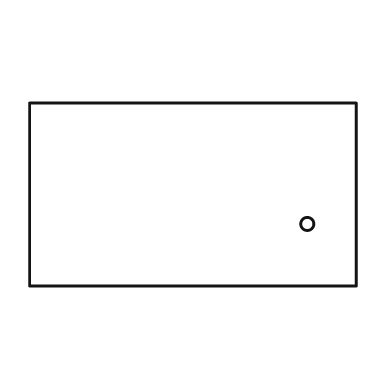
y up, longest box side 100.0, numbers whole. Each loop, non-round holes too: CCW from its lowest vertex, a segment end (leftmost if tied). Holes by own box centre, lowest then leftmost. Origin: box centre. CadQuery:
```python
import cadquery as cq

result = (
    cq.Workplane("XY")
    .moveTo(-50.0, -28.0)
    .lineTo(50.0, -28.0)
    .lineTo(50.0, 28.0)
    .lineTo(-50.0, 28.0)
    .close()
    .moveTo(35.0, -9.0)
    .circle(2.0)
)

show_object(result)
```